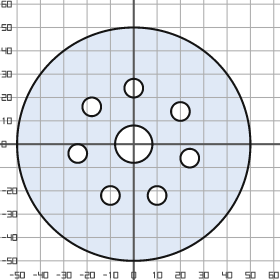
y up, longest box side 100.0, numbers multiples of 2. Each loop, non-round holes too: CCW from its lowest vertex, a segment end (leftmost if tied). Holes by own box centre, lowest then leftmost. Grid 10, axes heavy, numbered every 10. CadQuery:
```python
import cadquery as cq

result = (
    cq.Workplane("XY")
    .moveTo(0.0, 0.0)
    .circle(50.0)
    .moveTo(-10.0, -22.0)
    .circle(4.0)
    .moveTo(10.0, -22.0)
    .circle(4.0)
    .moveTo(24.0, -6.0)
    .circle(4.0)
    .moveTo(-24.0, -4.0)
    .circle(4.0)
    .moveTo(0.0, 0.0)
    .circle(8.0)
    .moveTo(20.0, 14.0)
    .circle(4.0)
    .moveTo(-18.0, 16.0)
    .circle(4.0)
    .moveTo(0.0, 24.0)
    .circle(4.0)
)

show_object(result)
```